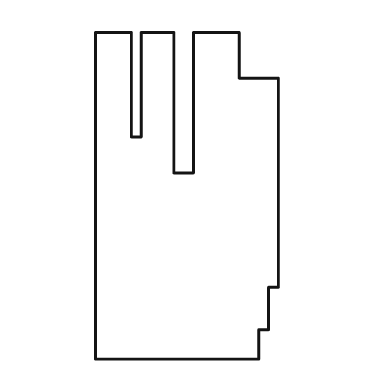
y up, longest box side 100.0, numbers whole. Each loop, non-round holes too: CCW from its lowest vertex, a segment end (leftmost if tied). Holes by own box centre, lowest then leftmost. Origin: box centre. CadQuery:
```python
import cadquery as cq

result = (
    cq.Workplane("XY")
    .moveTo(-28.0, -50.0)
    .lineTo(22.0, -50.0)
    .lineTo(22.0, -41.0)
    .lineTo(25.0, -41.0)
    .lineTo(25.0, -28.0)
    .lineTo(28.0, -28.0)
    .lineTo(28.0, 36.0)
    .lineTo(16.0, 36.0)
    .lineTo(16.0, 50.0)
    .lineTo(2.0, 50.0)
    .lineTo(2.0, 7.0)
    .lineTo(-4.0, 7.0)
    .lineTo(-4.0, 50.0)
    .lineTo(-14.0, 50.0)
    .lineTo(-14.0, 18.0)
    .lineTo(-17.0, 18.0)
    .lineTo(-17.0, 50.0)
    .lineTo(-28.0, 50.0)
    .close()
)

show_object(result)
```